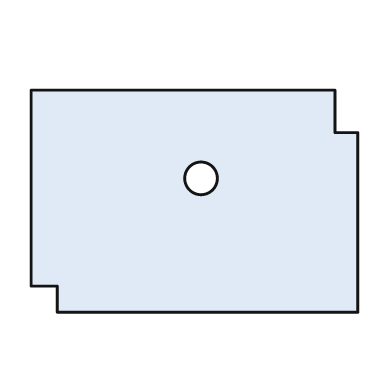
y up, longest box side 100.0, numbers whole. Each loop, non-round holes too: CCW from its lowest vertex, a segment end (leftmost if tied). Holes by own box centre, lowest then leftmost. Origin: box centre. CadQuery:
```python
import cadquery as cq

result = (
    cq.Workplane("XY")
    .moveTo(-42.0, -34.0)
    .lineTo(50.0, -34.0)
    .lineTo(50.0, 21.0)
    .lineTo(43.0, 21.0)
    .lineTo(43.0, 34.0)
    .lineTo(-50.0, 34.0)
    .lineTo(-50.0, -26.0)
    .lineTo(-42.0, -26.0)
    .close()
    .moveTo(2.0, 7.0)
    .circle(5.0)
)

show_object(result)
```